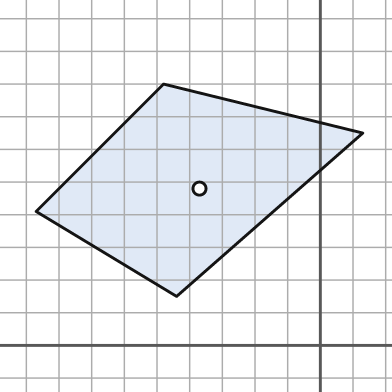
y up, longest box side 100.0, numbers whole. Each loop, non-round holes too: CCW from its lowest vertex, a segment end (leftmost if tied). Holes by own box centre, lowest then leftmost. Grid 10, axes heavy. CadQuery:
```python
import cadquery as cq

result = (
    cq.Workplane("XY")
    .moveTo(-44.0, 15.0)
    .lineTo(13.0, 65.0)
    .lineTo(-48.0, 80.0)
    .lineTo(-87.0, 41.0)
    .close()
    .moveTo(-37.0, 48.0)
    .circle(2.0)
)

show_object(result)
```